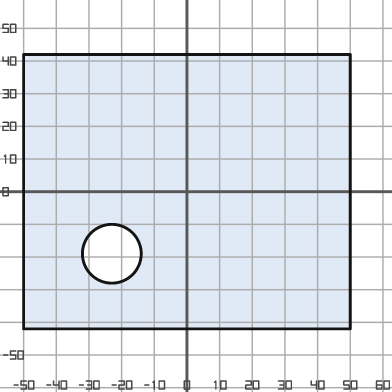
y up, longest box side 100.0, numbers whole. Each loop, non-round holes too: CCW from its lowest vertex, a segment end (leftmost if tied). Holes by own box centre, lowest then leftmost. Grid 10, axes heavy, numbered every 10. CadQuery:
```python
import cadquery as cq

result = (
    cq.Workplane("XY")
    .moveTo(-50.0, -42.0)
    .lineTo(50.0, -42.0)
    .lineTo(50.0, 42.0)
    .lineTo(-50.0, 42.0)
    .close()
    .moveTo(-23.0, -19.0)
    .circle(9.0)
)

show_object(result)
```